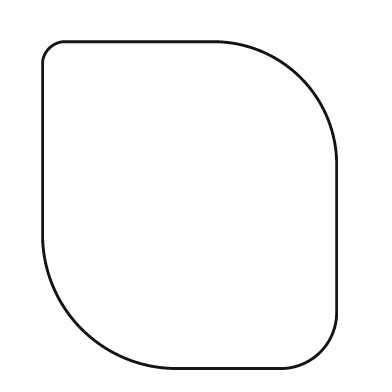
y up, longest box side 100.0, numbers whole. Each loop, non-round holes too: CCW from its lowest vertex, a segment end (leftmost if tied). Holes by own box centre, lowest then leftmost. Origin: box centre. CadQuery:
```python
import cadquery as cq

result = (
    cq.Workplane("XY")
    .moveTo(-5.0, -50.0)
    .lineTo(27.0, -50.0)
    .threePointArc((40.0, -45.0), (45.0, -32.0))
    .lineTo(45.0, 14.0)
    .threePointArc((34.0, 39.0), (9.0, 50.0))
    .lineTo(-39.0, 50.0)
    .threePointArc((-43.0, 48.0), (-45.0, 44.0))
    .lineTo(-45.0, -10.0)
    .threePointArc((-33.0, -38.0), (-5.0, -50.0))
    .close()
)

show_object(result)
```